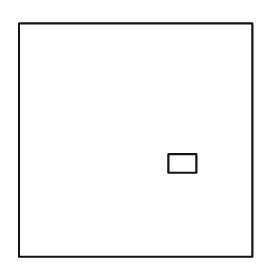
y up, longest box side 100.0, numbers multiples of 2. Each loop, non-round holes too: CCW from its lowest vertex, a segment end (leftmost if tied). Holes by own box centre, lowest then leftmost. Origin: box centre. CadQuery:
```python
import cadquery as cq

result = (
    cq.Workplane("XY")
    .moveTo(-50.0, -50.0)
    .lineTo(50.0, -50.0)
    .lineTo(50.0, 50.0)
    .lineTo(-50.0, 50.0)
    .close()
    .moveTo(14.0, -14.0)
    .lineTo(26.0, -14.0)
    .lineTo(26.0, -6.0)
    .lineTo(14.0, -6.0)
    .close()
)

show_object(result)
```